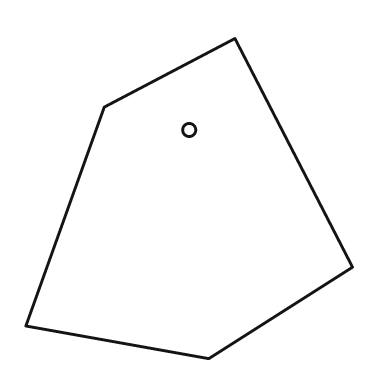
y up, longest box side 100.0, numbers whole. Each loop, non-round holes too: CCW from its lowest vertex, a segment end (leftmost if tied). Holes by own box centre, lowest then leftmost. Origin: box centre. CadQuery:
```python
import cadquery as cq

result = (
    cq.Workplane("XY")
    .moveTo(6.0, -49.0)
    .lineTo(50.0, -21.0)
    .lineTo(14.0, 49.0)
    .lineTo(-26.0, 28.0)
    .lineTo(-50.0, -39.0)
    .close()
    .moveTo(0.0, 21.0)
    .circle(2.0)
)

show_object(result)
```